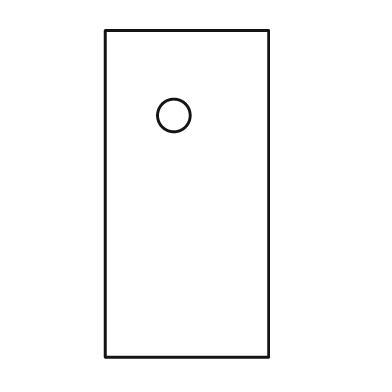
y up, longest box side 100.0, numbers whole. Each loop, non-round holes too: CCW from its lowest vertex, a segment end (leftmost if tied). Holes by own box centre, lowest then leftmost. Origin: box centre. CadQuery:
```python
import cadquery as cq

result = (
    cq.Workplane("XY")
    .moveTo(-25.0, -50.0)
    .lineTo(25.0, -50.0)
    .lineTo(25.0, 50.0)
    .lineTo(-25.0, 50.0)
    .close()
    .moveTo(-4.0, 24.0)
    .circle(5.0)
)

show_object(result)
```